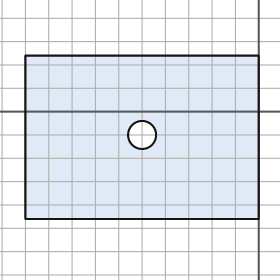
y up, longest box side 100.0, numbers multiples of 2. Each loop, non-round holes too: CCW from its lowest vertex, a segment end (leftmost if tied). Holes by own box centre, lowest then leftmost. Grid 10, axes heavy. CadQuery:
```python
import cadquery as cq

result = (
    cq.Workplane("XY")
    .moveTo(-100.0, -46.0)
    .lineTo(0.0, -46.0)
    .lineTo(0.0, 24.0)
    .lineTo(-100.0, 24.0)
    .close()
    .moveTo(-50.0, -10.0)
    .circle(6.0)
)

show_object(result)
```